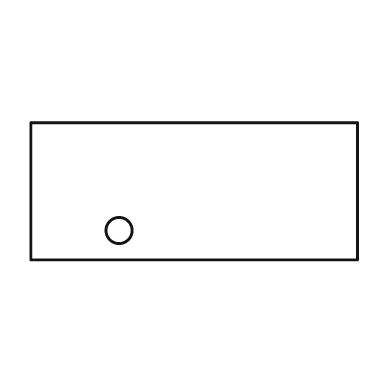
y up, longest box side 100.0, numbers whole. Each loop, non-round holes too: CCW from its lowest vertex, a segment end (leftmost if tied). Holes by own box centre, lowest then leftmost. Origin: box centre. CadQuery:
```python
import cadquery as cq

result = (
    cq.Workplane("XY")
    .moveTo(-50.0, -21.0)
    .lineTo(50.0, -21.0)
    .lineTo(50.0, 21.0)
    .lineTo(-50.0, 21.0)
    .close()
    .moveTo(-23.0, -12.0)
    .circle(4.0)
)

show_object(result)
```